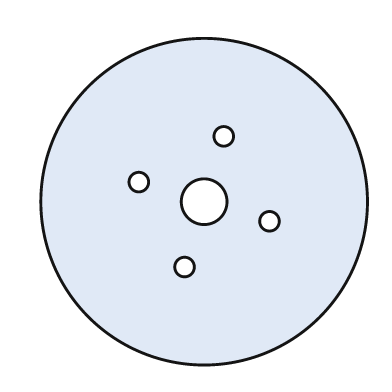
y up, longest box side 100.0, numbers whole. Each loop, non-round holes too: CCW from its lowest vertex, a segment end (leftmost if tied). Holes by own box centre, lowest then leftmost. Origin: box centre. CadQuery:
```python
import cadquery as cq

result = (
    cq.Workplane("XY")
    .moveTo(0.0, 0.0)
    .circle(50.0)
    .moveTo(-6.0, -20.0)
    .circle(3.0)
    .moveTo(20.0, -6.0)
    .circle(3.0)
    .moveTo(0.0, 0.0)
    .circle(7.0)
    .moveTo(-20.0, 6.0)
    .circle(3.0)
    .moveTo(6.0, 20.0)
    .circle(3.0)
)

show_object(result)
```